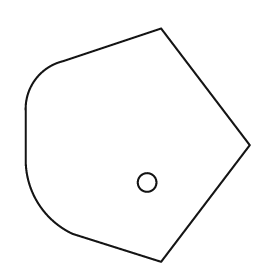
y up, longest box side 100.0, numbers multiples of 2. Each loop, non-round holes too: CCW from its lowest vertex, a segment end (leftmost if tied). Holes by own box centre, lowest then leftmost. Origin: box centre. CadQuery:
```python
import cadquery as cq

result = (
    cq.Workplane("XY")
    .moveTo(10.0, -50.0)
    .lineTo(48.0, 0.0)
    .lineTo(10.0, 50.0)
    .lineTo(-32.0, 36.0)
    .threePointArc((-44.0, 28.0), (-48.0, 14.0))
    .lineTo(-48.0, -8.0)
    .threePointArc((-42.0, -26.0), (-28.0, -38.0))
    .close()
    .moveTo(4.0, -16.0)
    .circle(4.0)
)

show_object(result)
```